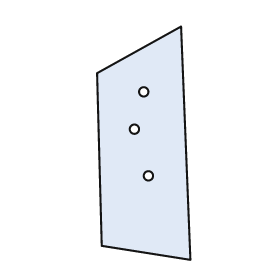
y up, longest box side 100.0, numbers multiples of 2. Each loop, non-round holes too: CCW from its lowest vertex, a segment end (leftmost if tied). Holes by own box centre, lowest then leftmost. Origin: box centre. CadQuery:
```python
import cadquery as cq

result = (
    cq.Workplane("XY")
    .moveTo(20.0, -50.0)
    .lineTo(16.0, 50.0)
    .lineTo(-20.0, 30.0)
    .lineTo(-18.0, -44.0)
    .close()
    .moveTo(2.0, -14.0)
    .circle(2.0)
    .moveTo(-4.0, 6.0)
    .circle(2.0)
    .moveTo(0.0, 22.0)
    .circle(2.0)
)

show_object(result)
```